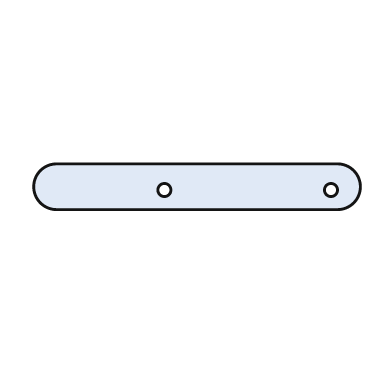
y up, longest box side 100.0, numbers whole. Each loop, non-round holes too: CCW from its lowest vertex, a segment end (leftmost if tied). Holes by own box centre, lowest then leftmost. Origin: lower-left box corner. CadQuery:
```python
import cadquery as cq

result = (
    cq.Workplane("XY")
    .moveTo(7.0, 0.0)
    .lineTo(93.0, 0.0)
    .threePointArc((100.0, 7.0), (93.0, 14.0))
    .lineTo(7.0, 14.0)
    .threePointArc((0.0, 7.0), (7.0, 0.0))
    .close()
    .moveTo(40.0, 6.0)
    .circle(2.0)
    .moveTo(91.0, 6.0)
    .circle(2.0)
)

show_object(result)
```